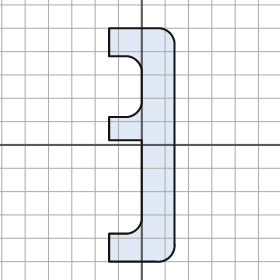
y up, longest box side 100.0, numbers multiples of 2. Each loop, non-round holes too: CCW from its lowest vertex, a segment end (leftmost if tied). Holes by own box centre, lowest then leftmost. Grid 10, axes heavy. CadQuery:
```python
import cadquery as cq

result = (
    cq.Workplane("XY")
    .moveTo(-14.0, -50.0)
    .lineTo(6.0, -50.0)
    .threePointArc((12.0, -48.0), (14.0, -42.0))
    .lineTo(14.0, 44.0)
    .threePointArc((12.0, 48.0), (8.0, 50.0))
    .lineTo(-14.0, 50.0)
    .lineTo(-14.0, 38.0)
    .lineTo(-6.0, 38.0)
    .threePointArc((-2.0, 36.0), (0.0, 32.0))
    .lineTo(0.0, 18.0)
    .threePointArc((-2.0, 14.0), (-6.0, 12.0))
    .lineTo(-14.0, 12.0)
    .lineTo(-14.0, 2.0)
    .lineTo(0.0, 2.0)
    .lineTo(0.0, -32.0)
    .threePointArc((-2.0, -36.0), (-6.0, -38.0))
    .lineTo(-14.0, -38.0)
    .close()
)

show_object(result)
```